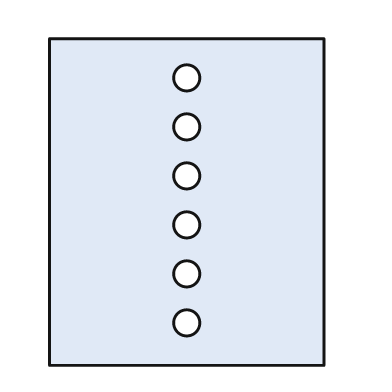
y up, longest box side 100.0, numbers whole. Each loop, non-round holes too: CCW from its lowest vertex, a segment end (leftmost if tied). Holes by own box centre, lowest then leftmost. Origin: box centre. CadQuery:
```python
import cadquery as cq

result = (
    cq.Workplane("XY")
    .moveTo(-42.0, -50.0)
    .lineTo(42.0, -50.0)
    .lineTo(42.0, 50.0)
    .lineTo(-42.0, 50.0)
    .close()
    .moveTo(0.0, -37.0)
    .circle(4.0)
    .moveTo(0.0, -22.0)
    .circle(4.0)
    .moveTo(0.0, -7.0)
    .circle(4.0)
    .moveTo(0.0, 8.0)
    .circle(4.0)
    .moveTo(0.0, 23.0)
    .circle(4.0)
    .moveTo(0.0, 38.0)
    .circle(4.0)
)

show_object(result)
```